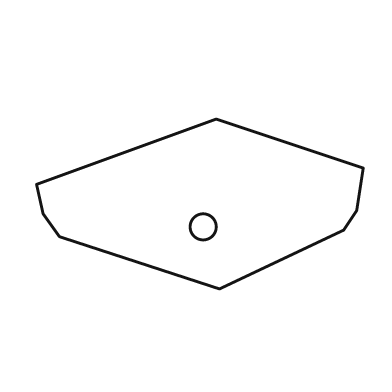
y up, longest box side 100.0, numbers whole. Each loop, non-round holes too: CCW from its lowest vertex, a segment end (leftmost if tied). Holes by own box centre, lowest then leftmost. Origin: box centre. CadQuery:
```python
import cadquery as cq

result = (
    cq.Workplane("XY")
    .moveTo(6.0, -26.0)
    .lineTo(44.0, -8.0)
    .lineTo(48.0, -2.0)
    .lineTo(50.0, 11.0)
    .lineTo(5.0, 26.0)
    .lineTo(-50.0, 6.0)
    .lineTo(-48.0, -3.0)
    .lineTo(-43.0, -10.0)
    .close()
    .moveTo(1.0, -7.0)
    .circle(4.0)
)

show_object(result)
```